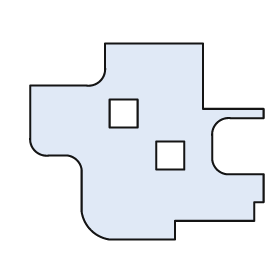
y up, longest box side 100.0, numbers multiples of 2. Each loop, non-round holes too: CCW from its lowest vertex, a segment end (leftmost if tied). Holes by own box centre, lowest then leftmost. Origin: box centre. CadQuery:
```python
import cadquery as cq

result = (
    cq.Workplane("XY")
    .moveTo(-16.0, -42.0)
    .lineTo(12.0, -42.0)
    .lineTo(12.0, -34.0)
    .lineTo(46.0, -34.0)
    .lineTo(46.0, -26.0)
    .lineTo(50.0, -26.0)
    .lineTo(50.0, -14.0)
    .lineTo(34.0, -14.0)
    .threePointArc((30.0, -12.0), (28.0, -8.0))
    .lineTo(28.0, 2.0)
    .threePointArc((30.0, 8.0), (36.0, 10.0))
    .lineTo(50.0, 10.0)
    .lineTo(50.0, 14.0)
    .lineTo(24.0, 14.0)
    .lineTo(24.0, 42.0)
    .lineTo(-18.0, 42.0)
    .lineTo(-18.0, 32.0)
    .threePointArc((-20.0, 26.0), (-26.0, 24.0))
    .lineTo(-50.0, 24.0)
    .lineTo(-50.0, 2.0)
    .threePointArc((-48.0, -4.0), (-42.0, -6.0))
    .lineTo(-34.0, -6.0)
    .threePointArc((-30.0, -8.0), (-28.0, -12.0))
    .lineTo(-28.0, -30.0)
    .threePointArc((-24.0, -38.0), (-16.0, -42.0))
    .close()
    .moveTo(4.0, -12.0)
    .lineTo(16.0, -12.0)
    .lineTo(16.0, 0.0)
    .lineTo(4.0, 0.0)
    .close()
    .moveTo(-16.0, 6.0)
    .lineTo(-4.0, 6.0)
    .lineTo(-4.0, 18.0)
    .lineTo(-16.0, 18.0)
    .close()
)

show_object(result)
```